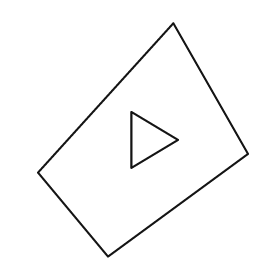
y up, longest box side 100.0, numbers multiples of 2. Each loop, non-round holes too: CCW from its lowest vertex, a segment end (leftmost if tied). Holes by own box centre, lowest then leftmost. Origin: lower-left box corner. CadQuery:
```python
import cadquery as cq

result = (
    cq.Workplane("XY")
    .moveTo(30.0, 0.0)
    .lineTo(90.0, 44.0)
    .lineTo(58.0, 100.0)
    .lineTo(0.0, 36.0)
    .close()
    .moveTo(40.0, 38.0)
    .lineTo(60.0, 50.0)
    .lineTo(40.0, 62.0)
    .close()
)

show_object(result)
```